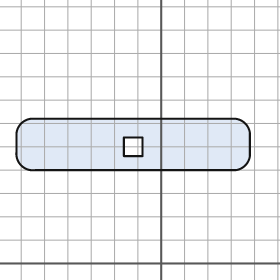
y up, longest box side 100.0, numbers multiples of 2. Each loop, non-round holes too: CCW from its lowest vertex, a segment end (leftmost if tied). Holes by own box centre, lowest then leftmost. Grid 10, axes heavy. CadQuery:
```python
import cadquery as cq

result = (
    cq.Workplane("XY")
    .moveTo(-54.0, 40.0)
    .lineTo(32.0, 40.0)
    .threePointArc((36.0, 42.0), (38.0, 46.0))
    .lineTo(38.0, 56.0)
    .threePointArc((36.0, 60.0), (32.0, 62.0))
    .lineTo(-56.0, 62.0)
    .threePointArc((-60.0, 60.0), (-62.0, 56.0))
    .lineTo(-62.0, 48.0)
    .threePointArc((-60.0, 42.0), (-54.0, 40.0))
    .close()
    .moveTo(-16.0, 46.0)
    .lineTo(-8.0, 46.0)
    .lineTo(-8.0, 54.0)
    .lineTo(-16.0, 54.0)
    .close()
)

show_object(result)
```